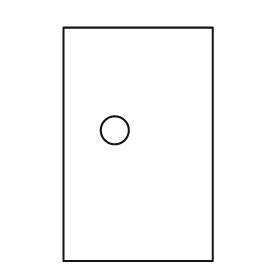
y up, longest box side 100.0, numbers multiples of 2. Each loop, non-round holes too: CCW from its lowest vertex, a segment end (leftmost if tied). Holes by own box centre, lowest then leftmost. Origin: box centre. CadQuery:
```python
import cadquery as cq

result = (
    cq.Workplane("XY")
    .moveTo(-32.0, -50.0)
    .lineTo(32.0, -50.0)
    .lineTo(32.0, 50.0)
    .lineTo(-32.0, 50.0)
    .close()
    .moveTo(-10.0, 6.0)
    .circle(6.0)
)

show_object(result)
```